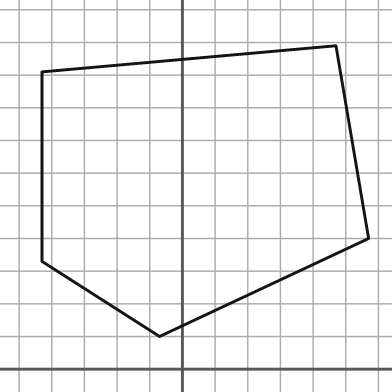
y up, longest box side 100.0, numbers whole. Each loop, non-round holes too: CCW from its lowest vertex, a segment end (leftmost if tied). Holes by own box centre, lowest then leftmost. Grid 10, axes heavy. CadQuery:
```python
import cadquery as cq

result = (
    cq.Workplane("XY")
    .moveTo(-7.0, 10.0)
    .lineTo(57.0, 40.0)
    .lineTo(47.0, 99.0)
    .lineTo(-43.0, 91.0)
    .lineTo(-43.0, 33.0)
    .close()
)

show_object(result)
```